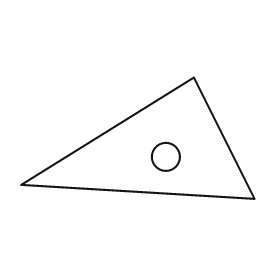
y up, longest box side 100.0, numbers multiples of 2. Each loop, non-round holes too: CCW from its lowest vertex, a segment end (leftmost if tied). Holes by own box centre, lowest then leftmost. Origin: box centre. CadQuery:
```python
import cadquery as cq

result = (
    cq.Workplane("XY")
    .moveTo(50.0, -26.0)
    .lineTo(24.0, 26.0)
    .lineTo(-50.0, -20.0)
    .close()
    .moveTo(12.0, -8.0)
    .circle(6.0)
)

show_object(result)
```